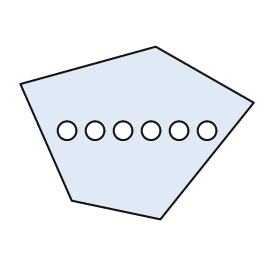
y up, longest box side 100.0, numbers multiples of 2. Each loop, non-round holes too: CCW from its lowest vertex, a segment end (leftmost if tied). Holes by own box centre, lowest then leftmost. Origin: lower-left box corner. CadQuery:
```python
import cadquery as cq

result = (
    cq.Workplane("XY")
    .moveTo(60.0, 0.0)
    .lineTo(100.0, 50.0)
    .lineTo(58.0, 74.0)
    .lineTo(0.0, 58.0)
    .lineTo(22.0, 8.0)
    .close()
    .moveTo(20.0, 38.0)
    .circle(4.0)
    .moveTo(32.0, 38.0)
    .circle(4.0)
    .moveTo(44.0, 38.0)
    .circle(4.0)
    .moveTo(56.0, 38.0)
    .circle(4.0)
    .moveTo(68.0, 38.0)
    .circle(4.0)
    .moveTo(80.0, 38.0)
    .circle(4.0)
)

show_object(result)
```